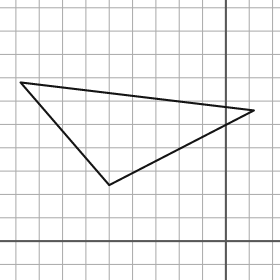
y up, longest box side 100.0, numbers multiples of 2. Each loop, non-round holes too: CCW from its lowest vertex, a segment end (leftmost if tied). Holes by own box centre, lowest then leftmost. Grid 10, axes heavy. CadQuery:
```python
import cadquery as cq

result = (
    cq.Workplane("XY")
    .moveTo(-50.0, 24.0)
    .lineTo(12.0, 56.0)
    .lineTo(-88.0, 68.0)
    .close()
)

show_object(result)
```